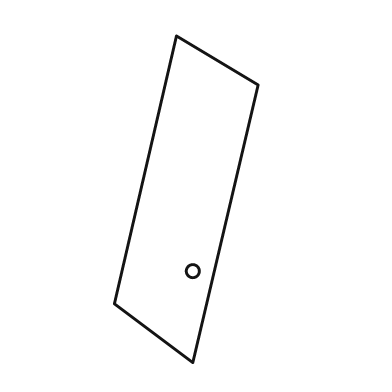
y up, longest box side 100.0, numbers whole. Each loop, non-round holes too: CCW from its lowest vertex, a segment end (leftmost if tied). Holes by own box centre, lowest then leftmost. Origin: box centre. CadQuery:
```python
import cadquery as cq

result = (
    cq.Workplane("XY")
    .moveTo(2.0, -50.0)
    .lineTo(22.0, 35.0)
    .lineTo(-3.0, 50.0)
    .lineTo(-22.0, -32.0)
    .close()
    .moveTo(2.0, -22.0)
    .circle(2.0)
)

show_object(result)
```